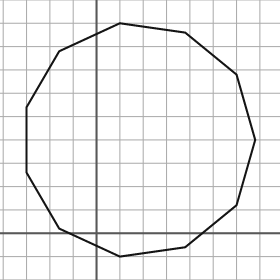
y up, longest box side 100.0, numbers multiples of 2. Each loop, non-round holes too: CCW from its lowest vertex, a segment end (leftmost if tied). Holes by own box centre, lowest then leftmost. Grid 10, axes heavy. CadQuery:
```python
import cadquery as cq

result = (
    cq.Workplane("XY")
    .moveTo(10.0, -10.0)
    .lineTo(38.0, -6.0)
    .lineTo(60.0, 12.0)
    .lineTo(68.0, 40.0)
    .lineTo(60.0, 68.0)
    .lineTo(38.0, 86.0)
    .lineTo(10.0, 90.0)
    .lineTo(-16.0, 78.0)
    .lineTo(-30.0, 54.0)
    .lineTo(-30.0, 26.0)
    .lineTo(-16.0, 2.0)
    .close()
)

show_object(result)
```